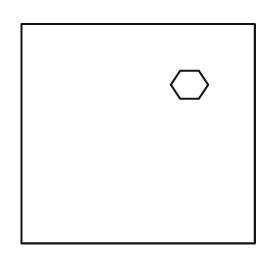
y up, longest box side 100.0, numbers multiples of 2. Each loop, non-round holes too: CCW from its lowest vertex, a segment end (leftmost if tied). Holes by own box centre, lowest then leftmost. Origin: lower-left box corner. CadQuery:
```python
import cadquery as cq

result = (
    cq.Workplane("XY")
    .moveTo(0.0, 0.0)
    .lineTo(100.0, 0.0)
    .lineTo(100.0, 94.0)
    .lineTo(0.0, 94.0)
    .close()
    .moveTo(68.0, 62.0)
    .lineTo(76.0, 62.0)
    .lineTo(80.0, 68.0)
    .lineTo(76.0, 74.0)
    .lineTo(68.0, 74.0)
    .lineTo(64.0, 68.0)
    .close()
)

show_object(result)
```